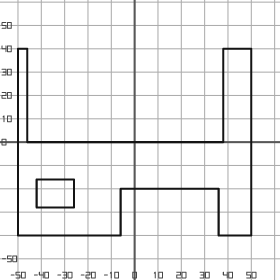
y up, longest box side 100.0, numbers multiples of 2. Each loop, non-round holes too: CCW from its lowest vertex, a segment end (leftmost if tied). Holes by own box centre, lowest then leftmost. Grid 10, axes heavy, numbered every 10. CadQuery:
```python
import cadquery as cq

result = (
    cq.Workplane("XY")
    .moveTo(-50.0, -40.0)
    .lineTo(-6.0, -40.0)
    .lineTo(-6.0, -20.0)
    .lineTo(36.0, -20.0)
    .lineTo(36.0, -40.0)
    .lineTo(50.0, -40.0)
    .lineTo(50.0, 40.0)
    .lineTo(38.0, 40.0)
    .lineTo(38.0, 0.0)
    .lineTo(-46.0, 0.0)
    .lineTo(-46.0, 40.0)
    .lineTo(-50.0, 40.0)
    .close()
    .moveTo(-42.0, -28.0)
    .lineTo(-26.0, -28.0)
    .lineTo(-26.0, -16.0)
    .lineTo(-42.0, -16.0)
    .close()
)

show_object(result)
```